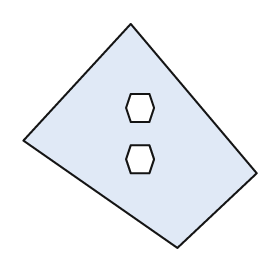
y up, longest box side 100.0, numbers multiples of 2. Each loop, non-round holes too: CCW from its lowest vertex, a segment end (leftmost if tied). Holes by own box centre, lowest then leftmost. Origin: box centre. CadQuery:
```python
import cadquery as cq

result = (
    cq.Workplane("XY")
    .moveTo(16.0, -48.0)
    .lineTo(50.0, -16.0)
    .lineTo(-4.0, 48.0)
    .lineTo(-50.0, -2.0)
    .close()
    .moveTo(-4.0, -16.0)
    .lineTo(4.0, -16.0)
    .lineTo(6.0, -10.0)
    .lineTo(4.0, -4.0)
    .lineTo(-4.0, -4.0)
    .lineTo(-6.0, -10.0)
    .close()
    .moveTo(-4.0, 6.0)
    .lineTo(4.0, 6.0)
    .lineTo(6.0, 12.0)
    .lineTo(4.0, 18.0)
    .lineTo(-4.0, 18.0)
    .lineTo(-6.0, 12.0)
    .close()
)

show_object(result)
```